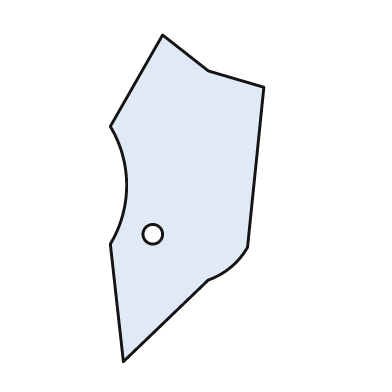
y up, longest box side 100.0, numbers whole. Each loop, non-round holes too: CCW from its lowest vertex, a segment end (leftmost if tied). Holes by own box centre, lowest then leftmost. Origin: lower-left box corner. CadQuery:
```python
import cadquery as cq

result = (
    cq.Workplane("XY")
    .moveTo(4.0, 0.0)
    .lineTo(30.0, 25.0)
    .threePointArc((37.0, 29.0), (42.0, 35.0))
    .lineTo(47.0, 84.0)
    .lineTo(30.0, 89.0)
    .lineTo(16.0, 100.0)
    .lineTo(0.0, 72.0)
    .threePointArc((5.0, 54.0), (0.0, 36.0))
    .close()
    .moveTo(13.0, 39.0)
    .circle(3.0)
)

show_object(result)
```